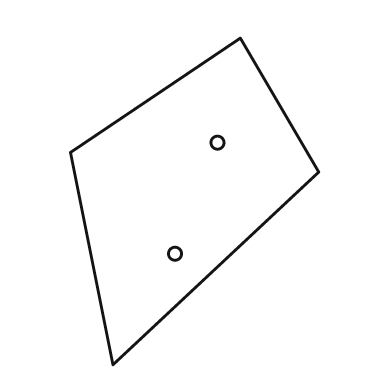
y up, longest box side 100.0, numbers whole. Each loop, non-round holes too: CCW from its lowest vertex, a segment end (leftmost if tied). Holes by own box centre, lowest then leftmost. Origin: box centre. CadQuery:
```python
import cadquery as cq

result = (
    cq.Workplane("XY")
    .moveTo(-25.0, -50.0)
    .lineTo(38.0, 9.0)
    .lineTo(14.0, 50.0)
    .lineTo(-38.0, 15.0)
    .close()
    .moveTo(-6.0, -16.0)
    .circle(2.0)
    .moveTo(7.0, 18.0)
    .circle(2.0)
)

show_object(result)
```